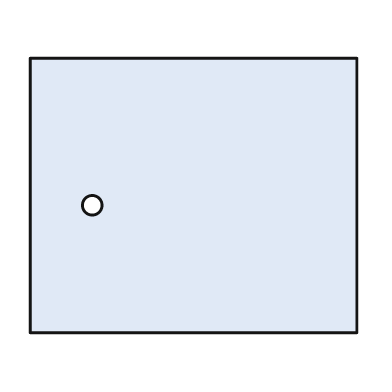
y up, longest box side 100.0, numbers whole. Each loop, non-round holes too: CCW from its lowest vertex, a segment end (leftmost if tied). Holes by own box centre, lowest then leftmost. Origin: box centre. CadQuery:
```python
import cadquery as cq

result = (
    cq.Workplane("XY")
    .moveTo(-50.0, -42.0)
    .lineTo(50.0, -42.0)
    .lineTo(50.0, 42.0)
    .lineTo(-50.0, 42.0)
    .close()
    .moveTo(-31.0, -3.0)
    .circle(3.0)
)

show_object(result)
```